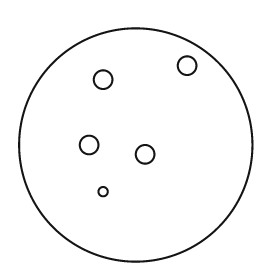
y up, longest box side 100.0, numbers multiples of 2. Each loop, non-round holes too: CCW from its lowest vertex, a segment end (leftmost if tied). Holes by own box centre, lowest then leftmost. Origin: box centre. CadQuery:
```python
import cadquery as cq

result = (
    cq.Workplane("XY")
    .moveTo(0.0, 0.0)
    .circle(50.0)
    .moveTo(-14.0, -20.0)
    .circle(2.0)
    .moveTo(4.0, -4.0)
    .circle(4.0)
    .moveTo(-20.0, 0.0)
    .circle(4.0)
    .moveTo(-14.0, 28.0)
    .circle(4.0)
    .moveTo(22.0, 34.0)
    .circle(4.0)
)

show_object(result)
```